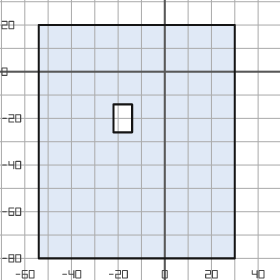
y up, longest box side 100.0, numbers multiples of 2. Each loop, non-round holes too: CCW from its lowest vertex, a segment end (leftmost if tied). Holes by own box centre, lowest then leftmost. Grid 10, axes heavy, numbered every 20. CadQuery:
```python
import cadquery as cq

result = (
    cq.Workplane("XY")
    .moveTo(-54.0, -80.0)
    .lineTo(30.0, -80.0)
    .lineTo(30.0, 20.0)
    .lineTo(-54.0, 20.0)
    .close()
    .moveTo(-22.0, -26.0)
    .lineTo(-14.0, -26.0)
    .lineTo(-14.0, -14.0)
    .lineTo(-22.0, -14.0)
    .close()
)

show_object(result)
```